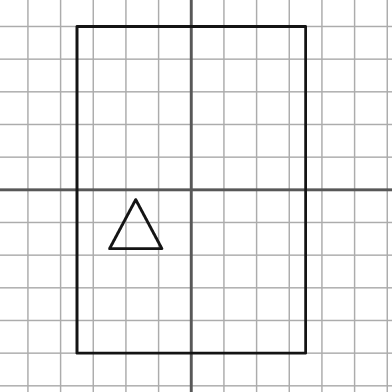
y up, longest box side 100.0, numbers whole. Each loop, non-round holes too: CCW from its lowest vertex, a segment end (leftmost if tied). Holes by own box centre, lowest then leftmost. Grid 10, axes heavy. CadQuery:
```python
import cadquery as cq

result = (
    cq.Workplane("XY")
    .moveTo(-35.0, -50.0)
    .lineTo(35.0, -50.0)
    .lineTo(35.0, 50.0)
    .lineTo(-35.0, 50.0)
    .close()
    .moveTo(-25.0, -18.0)
    .lineTo(-9.0, -18.0)
    .lineTo(-17.0, -3.0)
    .close()
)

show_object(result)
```